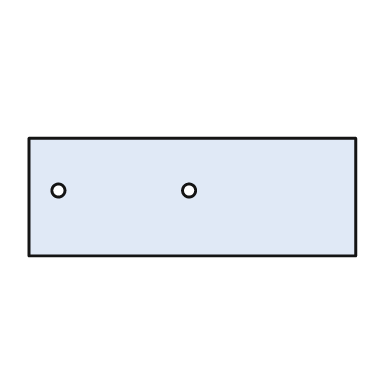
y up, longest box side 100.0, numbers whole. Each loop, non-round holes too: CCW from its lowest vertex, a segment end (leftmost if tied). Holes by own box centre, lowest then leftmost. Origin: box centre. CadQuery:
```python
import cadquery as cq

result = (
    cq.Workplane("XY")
    .moveTo(-50.0, -18.0)
    .lineTo(50.0, -18.0)
    .lineTo(50.0, 18.0)
    .lineTo(-50.0, 18.0)
    .close()
    .moveTo(-41.0, 2.0)
    .circle(2.0)
    .moveTo(-1.0, 2.0)
    .circle(2.0)
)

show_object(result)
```